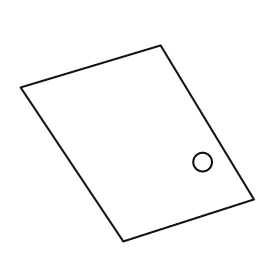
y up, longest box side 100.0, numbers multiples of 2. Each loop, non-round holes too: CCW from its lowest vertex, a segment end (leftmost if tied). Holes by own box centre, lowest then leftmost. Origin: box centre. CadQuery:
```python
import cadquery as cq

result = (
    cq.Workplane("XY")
    .moveTo(-6.0, -42.0)
    .lineTo(50.0, -24.0)
    .lineTo(10.0, 42.0)
    .lineTo(-50.0, 24.0)
    .close()
    .moveTo(28.0, -8.0)
    .circle(4.0)
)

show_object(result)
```